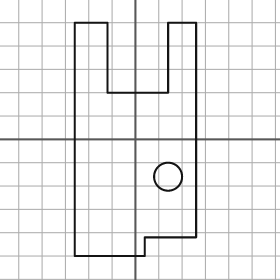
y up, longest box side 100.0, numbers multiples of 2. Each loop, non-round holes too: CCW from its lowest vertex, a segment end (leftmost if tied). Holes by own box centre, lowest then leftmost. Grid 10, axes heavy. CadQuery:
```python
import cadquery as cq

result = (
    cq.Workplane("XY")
    .moveTo(-26.0, -50.0)
    .lineTo(4.0, -50.0)
    .lineTo(4.0, -42.0)
    .lineTo(26.0, -42.0)
    .lineTo(26.0, 50.0)
    .lineTo(14.0, 50.0)
    .lineTo(14.0, 20.0)
    .lineTo(-12.0, 20.0)
    .lineTo(-12.0, 50.0)
    .lineTo(-26.0, 50.0)
    .close()
    .moveTo(14.0, -16.0)
    .circle(6.0)
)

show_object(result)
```